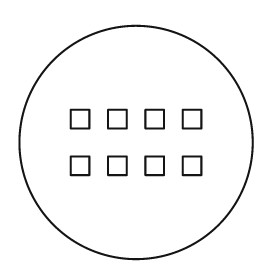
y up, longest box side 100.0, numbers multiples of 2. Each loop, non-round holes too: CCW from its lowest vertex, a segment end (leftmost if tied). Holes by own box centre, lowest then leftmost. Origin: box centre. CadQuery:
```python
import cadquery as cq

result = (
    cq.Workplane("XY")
    .moveTo(0.0, 0.0)
    .circle(50.0)
    .moveTo(-28.0, -14.0)
    .lineTo(-20.0, -14.0)
    .lineTo(-20.0, -6.0)
    .lineTo(-28.0, -6.0)
    .close()
    .moveTo(-12.0, -14.0)
    .lineTo(-4.0, -14.0)
    .lineTo(-4.0, -6.0)
    .lineTo(-12.0, -6.0)
    .close()
    .moveTo(4.0, -14.0)
    .lineTo(12.0, -14.0)
    .lineTo(12.0, -6.0)
    .lineTo(4.0, -6.0)
    .close()
    .moveTo(20.0, -14.0)
    .lineTo(28.0, -14.0)
    .lineTo(28.0, -6.0)
    .lineTo(20.0, -6.0)
    .close()
    .moveTo(-28.0, 6.0)
    .lineTo(-20.0, 6.0)
    .lineTo(-20.0, 14.0)
    .lineTo(-28.0, 14.0)
    .close()
    .moveTo(-12.0, 6.0)
    .lineTo(-4.0, 6.0)
    .lineTo(-4.0, 14.0)
    .lineTo(-12.0, 14.0)
    .close()
    .moveTo(4.0, 6.0)
    .lineTo(12.0, 6.0)
    .lineTo(12.0, 14.0)
    .lineTo(4.0, 14.0)
    .close()
    .moveTo(20.0, 6.0)
    .lineTo(28.0, 6.0)
    .lineTo(28.0, 14.0)
    .lineTo(20.0, 14.0)
    .close()
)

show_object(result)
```